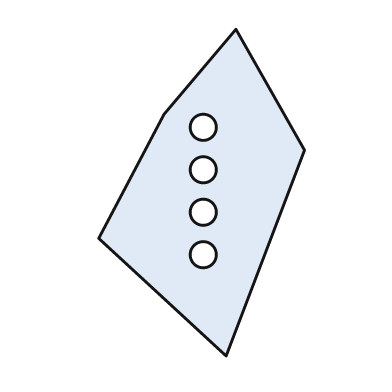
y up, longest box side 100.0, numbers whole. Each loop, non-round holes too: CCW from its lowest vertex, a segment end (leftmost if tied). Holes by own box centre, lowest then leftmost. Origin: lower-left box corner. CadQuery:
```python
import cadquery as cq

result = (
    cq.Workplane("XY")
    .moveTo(39.0, 0.0)
    .lineTo(63.0, 63.0)
    .lineTo(42.0, 100.0)
    .lineTo(20.0, 74.0)
    .lineTo(0.0, 36.0)
    .close()
    .moveTo(32.0, 31.0)
    .circle(4.0)
    .moveTo(32.0, 44.0)
    .circle(4.0)
    .moveTo(32.0, 57.0)
    .circle(4.0)
    .moveTo(32.0, 70.0)
    .circle(4.0)
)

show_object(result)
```